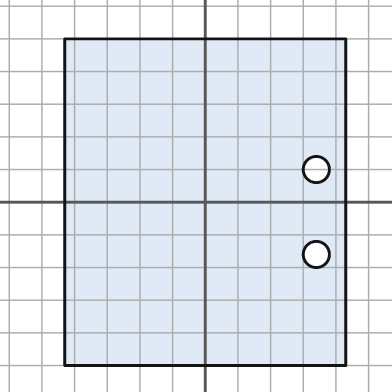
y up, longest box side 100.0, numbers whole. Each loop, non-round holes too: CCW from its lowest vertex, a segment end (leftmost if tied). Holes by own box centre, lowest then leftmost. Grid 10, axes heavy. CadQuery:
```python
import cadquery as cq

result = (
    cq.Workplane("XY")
    .moveTo(-43.0, -50.0)
    .lineTo(43.0, -50.0)
    .lineTo(43.0, 50.0)
    .lineTo(-43.0, 50.0)
    .close()
    .moveTo(34.0, -16.0)
    .circle(4.0)
    .moveTo(34.0, 10.0)
    .circle(4.0)
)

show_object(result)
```